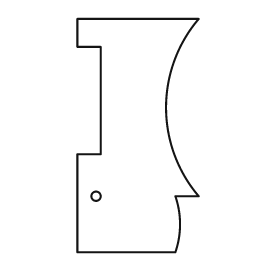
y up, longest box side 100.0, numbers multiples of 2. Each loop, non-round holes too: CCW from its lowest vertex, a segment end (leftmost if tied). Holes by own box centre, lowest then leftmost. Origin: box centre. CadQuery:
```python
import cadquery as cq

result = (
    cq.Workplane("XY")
    .moveTo(-26.0, -50.0)
    .lineTo(16.0, -50.0)
    .threePointArc((18.0, -38.0), (16.0, -26.0))
    .lineTo(26.0, -26.0)
    .threePointArc((12.0, 12.0), (26.0, 50.0))
    .lineTo(-26.0, 50.0)
    .lineTo(-26.0, 38.0)
    .lineTo(-16.0, 38.0)
    .lineTo(-16.0, -8.0)
    .lineTo(-26.0, -8.0)
    .close()
    .moveTo(-18.0, -26.0)
    .circle(2.0)
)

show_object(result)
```